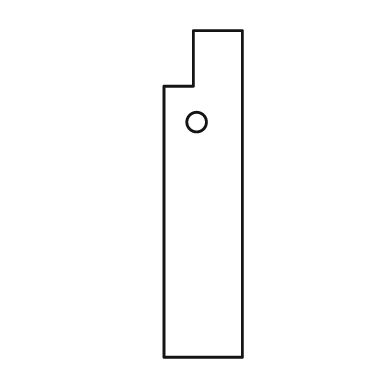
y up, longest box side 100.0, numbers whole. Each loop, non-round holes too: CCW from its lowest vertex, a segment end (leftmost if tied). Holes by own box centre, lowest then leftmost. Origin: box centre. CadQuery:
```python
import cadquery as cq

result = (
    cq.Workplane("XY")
    .moveTo(-12.0, -50.0)
    .lineTo(12.0, -50.0)
    .lineTo(12.0, 50.0)
    .lineTo(-3.0, 50.0)
    .lineTo(-3.0, 33.0)
    .lineTo(-12.0, 33.0)
    .close()
    .moveTo(-2.0, 22.0)
    .circle(3.0)
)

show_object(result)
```